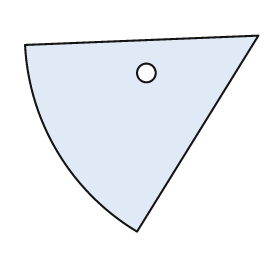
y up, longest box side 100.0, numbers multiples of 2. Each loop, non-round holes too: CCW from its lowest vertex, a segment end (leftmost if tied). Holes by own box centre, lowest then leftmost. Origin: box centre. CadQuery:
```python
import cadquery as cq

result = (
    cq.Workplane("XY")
    .moveTo(-2.0, -42.0)
    .lineTo(50.0, 42.0)
    .lineTo(-50.0, 38.0)
    .threePointArc((-36.0, -8.0), (-2.0, -42.0))
    .close()
    .moveTo(2.0, 26.0)
    .circle(4.0)
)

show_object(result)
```